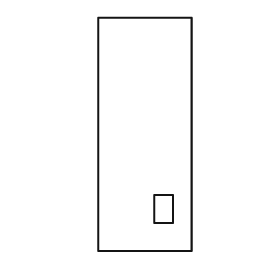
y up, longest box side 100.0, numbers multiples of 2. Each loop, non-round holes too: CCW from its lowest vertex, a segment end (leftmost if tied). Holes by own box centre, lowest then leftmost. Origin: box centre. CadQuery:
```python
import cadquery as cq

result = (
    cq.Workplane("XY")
    .moveTo(-20.0, -50.0)
    .lineTo(20.0, -50.0)
    .lineTo(20.0, 50.0)
    .lineTo(-20.0, 50.0)
    .close()
    .moveTo(4.0, -38.0)
    .lineTo(12.0, -38.0)
    .lineTo(12.0, -26.0)
    .lineTo(4.0, -26.0)
    .close()
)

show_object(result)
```